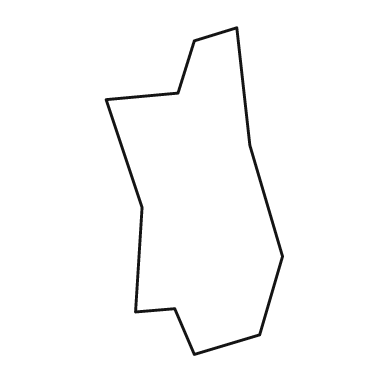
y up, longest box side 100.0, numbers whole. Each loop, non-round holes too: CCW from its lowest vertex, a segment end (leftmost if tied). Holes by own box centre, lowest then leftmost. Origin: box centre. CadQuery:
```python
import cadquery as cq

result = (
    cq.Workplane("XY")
    .moveTo(0.0, -50.0)
    .lineTo(20.0, -44.0)
    .lineTo(27.0, -20.0)
    .lineTo(17.0, 14.0)
    .lineTo(13.0, 50.0)
    .lineTo(0.0, 46.0)
    .lineTo(-5.0, 30.0)
    .lineTo(-27.0, 28.0)
    .lineTo(-16.0, -5.0)
    .lineTo(-18.0, -37.0)
    .lineTo(-6.0, -36.0)
    .close()
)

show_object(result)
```